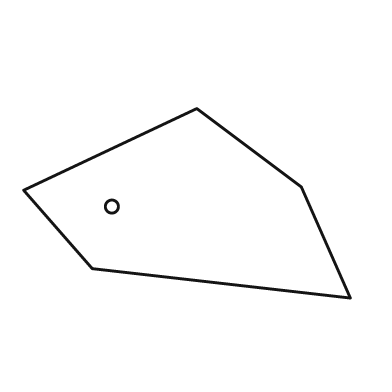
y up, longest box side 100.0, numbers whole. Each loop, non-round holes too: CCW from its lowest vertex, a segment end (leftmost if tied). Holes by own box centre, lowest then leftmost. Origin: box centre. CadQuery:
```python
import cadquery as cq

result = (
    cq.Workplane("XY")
    .moveTo(50.0, -29.0)
    .lineTo(35.0, 5.0)
    .lineTo(3.0, 29.0)
    .lineTo(-50.0, 4.0)
    .lineTo(-29.0, -20.0)
    .close()
    .moveTo(-23.0, -1.0)
    .circle(2.0)
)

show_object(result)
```